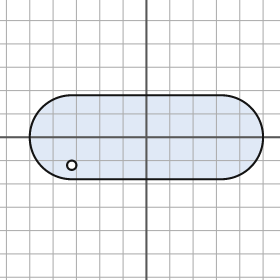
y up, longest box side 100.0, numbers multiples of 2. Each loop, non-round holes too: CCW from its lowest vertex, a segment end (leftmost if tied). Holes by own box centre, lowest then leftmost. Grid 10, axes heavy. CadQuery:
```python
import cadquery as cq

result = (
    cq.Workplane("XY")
    .moveTo(-32.0, -18.0)
    .lineTo(32.0, -18.0)
    .threePointArc((50.0, 0.0), (32.0, 18.0))
    .lineTo(-32.0, 18.0)
    .threePointArc((-50.0, 0.0), (-32.0, -18.0))
    .close()
    .moveTo(-32.0, -12.0)
    .circle(2.0)
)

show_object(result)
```